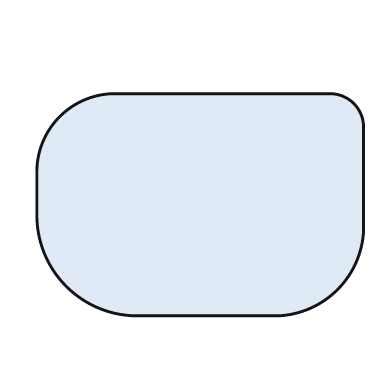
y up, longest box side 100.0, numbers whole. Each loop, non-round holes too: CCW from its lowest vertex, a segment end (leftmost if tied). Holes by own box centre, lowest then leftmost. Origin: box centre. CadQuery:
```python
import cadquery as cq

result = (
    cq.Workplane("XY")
    .moveTo(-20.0, -34.0)
    .lineTo(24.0, -34.0)
    .threePointArc((42.0, -26.0), (50.0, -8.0))
    .lineTo(50.0, 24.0)
    .threePointArc((47.0, 31.0), (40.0, 34.0))
    .lineTo(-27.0, 34.0)
    .threePointArc((-43.0, 27.0), (-50.0, 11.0))
    .lineTo(-50.0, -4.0)
    .threePointArc((-41.0, -25.0), (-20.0, -34.0))
    .close()
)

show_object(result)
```